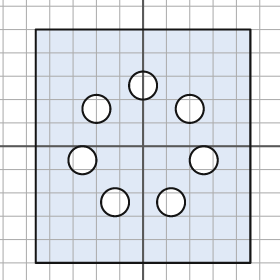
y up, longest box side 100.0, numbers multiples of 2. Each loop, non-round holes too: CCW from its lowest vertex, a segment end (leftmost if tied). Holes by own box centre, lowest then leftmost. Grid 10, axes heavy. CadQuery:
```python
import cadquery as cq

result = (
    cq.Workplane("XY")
    .moveTo(-46.0, -50.0)
    .lineTo(46.0, -50.0)
    .lineTo(46.0, 50.0)
    .lineTo(-46.0, 50.0)
    .close()
    .moveTo(-12.0, -24.0)
    .circle(6.0)
    .moveTo(12.0, -24.0)
    .circle(6.0)
    .moveTo(-26.0, -6.0)
    .circle(6.0)
    .moveTo(26.0, -6.0)
    .circle(6.0)
    .moveTo(-20.0, 16.0)
    .circle(6.0)
    .moveTo(20.0, 16.0)
    .circle(6.0)
    .moveTo(0.0, 26.0)
    .circle(6.0)
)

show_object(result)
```